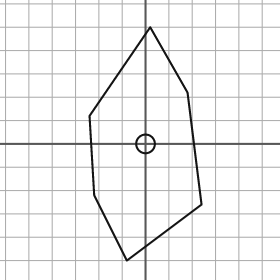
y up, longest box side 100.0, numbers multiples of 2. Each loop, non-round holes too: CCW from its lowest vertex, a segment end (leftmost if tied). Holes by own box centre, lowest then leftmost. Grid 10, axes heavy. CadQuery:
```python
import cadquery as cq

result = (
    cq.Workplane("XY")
    .moveTo(-8.0, -50.0)
    .lineTo(24.0, -26.0)
    .lineTo(18.0, 22.0)
    .lineTo(2.0, 50.0)
    .lineTo(-24.0, 12.0)
    .lineTo(-22.0, -22.0)
    .close()
    .moveTo(0.0, 0.0)
    .circle(4.0)
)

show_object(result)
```